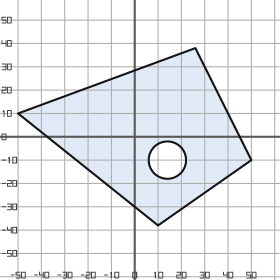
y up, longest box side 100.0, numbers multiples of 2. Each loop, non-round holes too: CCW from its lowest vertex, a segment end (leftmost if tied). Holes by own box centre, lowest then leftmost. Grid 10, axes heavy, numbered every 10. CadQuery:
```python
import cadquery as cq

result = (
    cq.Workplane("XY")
    .moveTo(10.0, -38.0)
    .lineTo(50.0, -10.0)
    .lineTo(26.0, 38.0)
    .lineTo(-50.0, 10.0)
    .close()
    .moveTo(14.0, -10.0)
    .circle(8.0)
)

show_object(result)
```